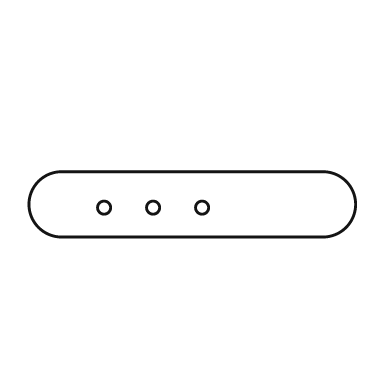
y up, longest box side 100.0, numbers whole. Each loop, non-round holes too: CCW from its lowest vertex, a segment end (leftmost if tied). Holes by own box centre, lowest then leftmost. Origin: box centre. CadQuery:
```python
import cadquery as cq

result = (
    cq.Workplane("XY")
    .moveTo(-40.0, -10.0)
    .lineTo(40.0, -10.0)
    .threePointArc((50.0, 0.0), (40.0, 10.0))
    .lineTo(-40.0, 10.0)
    .threePointArc((-50.0, 0.0), (-40.0, -10.0))
    .close()
    .moveTo(-27.0, -1.0)
    .circle(2.0)
    .moveTo(-12.0, -1.0)
    .circle(2.0)
    .moveTo(3.0, -1.0)
    .circle(2.0)
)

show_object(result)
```